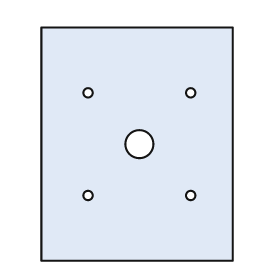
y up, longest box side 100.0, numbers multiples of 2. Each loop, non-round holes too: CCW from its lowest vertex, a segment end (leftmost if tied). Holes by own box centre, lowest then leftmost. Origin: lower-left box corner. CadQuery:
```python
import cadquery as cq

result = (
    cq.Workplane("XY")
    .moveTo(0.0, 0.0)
    .lineTo(82.0, 0.0)
    .lineTo(82.0, 100.0)
    .lineTo(0.0, 100.0)
    .close()
    .moveTo(20.0, 28.0)
    .circle(2.0)
    .moveTo(64.0, 28.0)
    .circle(2.0)
    .moveTo(42.0, 50.0)
    .circle(6.0)
    .moveTo(20.0, 72.0)
    .circle(2.0)
    .moveTo(64.0, 72.0)
    .circle(2.0)
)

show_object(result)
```